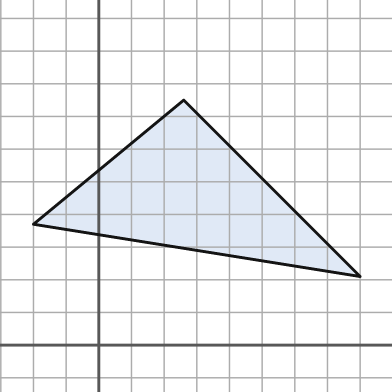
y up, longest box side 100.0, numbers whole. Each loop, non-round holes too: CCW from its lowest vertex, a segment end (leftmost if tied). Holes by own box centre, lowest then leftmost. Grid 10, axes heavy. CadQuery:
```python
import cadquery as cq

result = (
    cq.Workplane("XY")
    .moveTo(80.0, 21.0)
    .lineTo(26.0, 75.0)
    .lineTo(-20.0, 37.0)
    .close()
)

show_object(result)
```